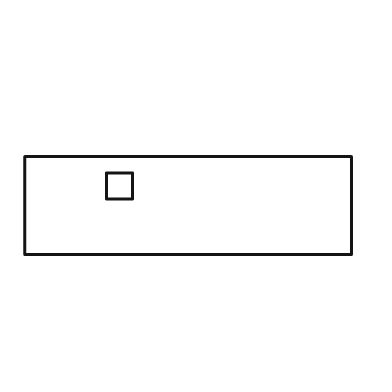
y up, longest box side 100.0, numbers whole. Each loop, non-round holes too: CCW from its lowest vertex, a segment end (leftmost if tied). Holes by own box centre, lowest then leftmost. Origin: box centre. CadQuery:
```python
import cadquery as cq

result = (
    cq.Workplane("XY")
    .moveTo(-50.0, -15.0)
    .lineTo(50.0, -15.0)
    .lineTo(50.0, 15.0)
    .lineTo(-50.0, 15.0)
    .close()
    .moveTo(-25.0, 2.0)
    .lineTo(-17.0, 2.0)
    .lineTo(-17.0, 10.0)
    .lineTo(-25.0, 10.0)
    .close()
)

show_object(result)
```